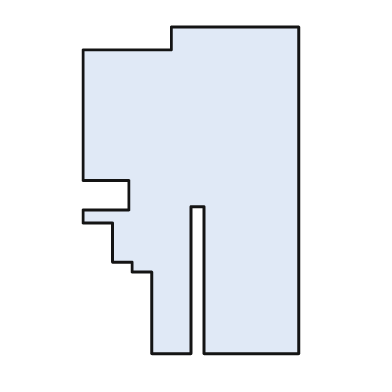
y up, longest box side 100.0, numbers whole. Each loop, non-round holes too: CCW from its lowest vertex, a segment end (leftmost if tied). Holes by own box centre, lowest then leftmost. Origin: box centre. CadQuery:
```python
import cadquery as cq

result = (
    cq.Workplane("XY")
    .moveTo(-12.0, -50.0)
    .lineTo(0.0, -50.0)
    .lineTo(0.0, -5.0)
    .lineTo(4.0, -5.0)
    .lineTo(4.0, -50.0)
    .lineTo(33.0, -50.0)
    .lineTo(33.0, 50.0)
    .lineTo(-6.0, 50.0)
    .lineTo(-6.0, 43.0)
    .lineTo(-33.0, 43.0)
    .lineTo(-33.0, 3.0)
    .lineTo(-19.0, 3.0)
    .lineTo(-19.0, -6.0)
    .lineTo(-33.0, -6.0)
    .lineTo(-33.0, -10.0)
    .lineTo(-24.0, -10.0)
    .lineTo(-24.0, -22.0)
    .lineTo(-18.0, -22.0)
    .lineTo(-18.0, -25.0)
    .lineTo(-12.0, -25.0)
    .close()
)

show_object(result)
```